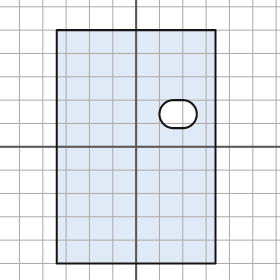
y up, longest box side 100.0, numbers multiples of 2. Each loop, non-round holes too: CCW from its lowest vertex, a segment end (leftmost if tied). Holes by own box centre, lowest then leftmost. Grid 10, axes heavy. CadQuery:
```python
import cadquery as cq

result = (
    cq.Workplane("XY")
    .moveTo(-34.0, -50.0)
    .lineTo(34.0, -50.0)
    .lineTo(34.0, 50.0)
    .lineTo(-34.0, 50.0)
    .close()
    .moveTo(16.0, 8.0)
    .lineTo(20.0, 8.0)
    .threePointArc((26.0, 14.0), (20.0, 20.0))
    .lineTo(16.0, 20.0)
    .threePointArc((10.0, 14.0), (16.0, 8.0))
    .close()
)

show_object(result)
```